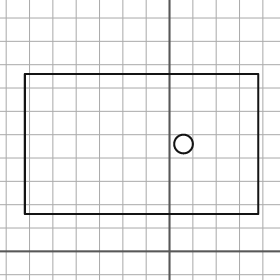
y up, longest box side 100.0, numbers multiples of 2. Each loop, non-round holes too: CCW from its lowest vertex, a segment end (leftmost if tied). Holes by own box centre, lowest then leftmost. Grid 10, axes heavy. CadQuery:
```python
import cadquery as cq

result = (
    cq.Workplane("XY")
    .moveTo(-62.0, 16.0)
    .lineTo(38.0, 16.0)
    .lineTo(38.0, 76.0)
    .lineTo(-62.0, 76.0)
    .close()
    .moveTo(6.0, 46.0)
    .circle(4.0)
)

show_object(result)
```